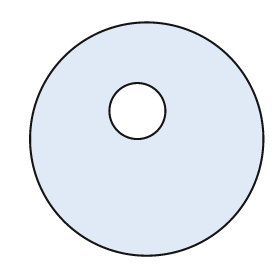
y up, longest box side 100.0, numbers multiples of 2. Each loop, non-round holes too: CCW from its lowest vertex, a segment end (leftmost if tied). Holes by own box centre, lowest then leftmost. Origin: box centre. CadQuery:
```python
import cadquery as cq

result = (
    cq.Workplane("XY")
    .moveTo(0.0, 0.0)
    .circle(50.0)
    .moveTo(-4.0, 12.0)
    .circle(12.0)
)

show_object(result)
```